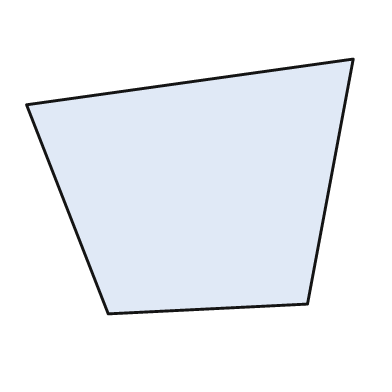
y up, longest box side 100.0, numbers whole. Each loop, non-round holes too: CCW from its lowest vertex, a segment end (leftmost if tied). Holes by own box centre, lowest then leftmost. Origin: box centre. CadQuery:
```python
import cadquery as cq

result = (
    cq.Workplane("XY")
    .moveTo(-25.0, -39.0)
    .lineTo(36.0, -36.0)
    .lineTo(50.0, 39.0)
    .lineTo(-50.0, 25.0)
    .close()
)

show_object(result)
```